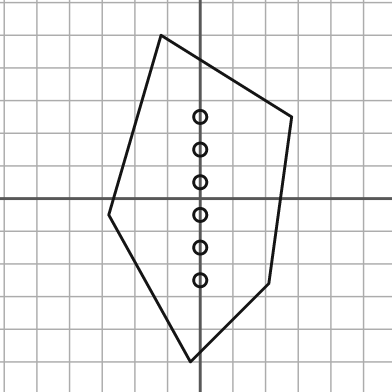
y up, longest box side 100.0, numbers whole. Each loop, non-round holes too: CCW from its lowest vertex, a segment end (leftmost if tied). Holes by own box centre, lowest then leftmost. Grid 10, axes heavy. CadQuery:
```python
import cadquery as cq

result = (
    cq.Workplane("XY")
    .moveTo(-3.0, -50.0)
    .lineTo(21.0, -26.0)
    .lineTo(28.0, 25.0)
    .lineTo(-12.0, 50.0)
    .lineTo(-28.0, -5.0)
    .close()
    .moveTo(0.0, -25.0)
    .circle(2.0)
    .moveTo(0.0, -15.0)
    .circle(2.0)
    .moveTo(0.0, -5.0)
    .circle(2.0)
    .moveTo(0.0, 5.0)
    .circle(2.0)
    .moveTo(0.0, 15.0)
    .circle(2.0)
    .moveTo(0.0, 25.0)
    .circle(2.0)
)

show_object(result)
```